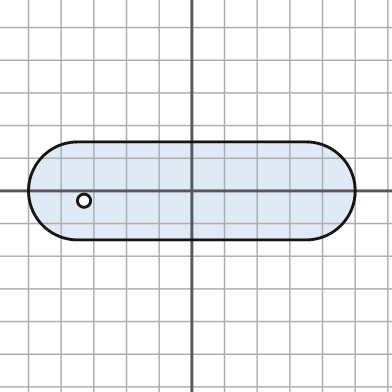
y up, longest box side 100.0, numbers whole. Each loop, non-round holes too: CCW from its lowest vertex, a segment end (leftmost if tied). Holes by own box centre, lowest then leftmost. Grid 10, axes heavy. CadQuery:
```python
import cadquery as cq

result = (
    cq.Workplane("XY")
    .moveTo(-35.0, -15.0)
    .lineTo(35.0, -15.0)
    .threePointArc((50.0, 0.0), (35.0, 15.0))
    .lineTo(-35.0, 15.0)
    .threePointArc((-50.0, 0.0), (-35.0, -15.0))
    .close()
    .moveTo(-33.0, -3.0)
    .circle(2.0)
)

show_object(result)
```